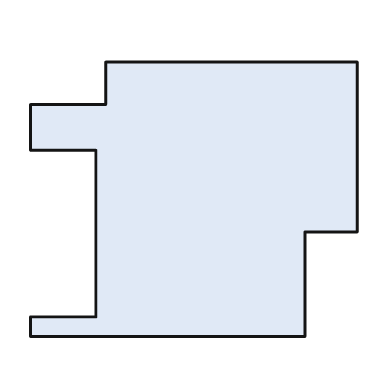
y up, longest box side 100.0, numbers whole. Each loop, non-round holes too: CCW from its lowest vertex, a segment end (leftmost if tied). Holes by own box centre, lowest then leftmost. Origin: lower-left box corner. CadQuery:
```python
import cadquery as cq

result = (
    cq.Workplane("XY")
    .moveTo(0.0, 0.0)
    .lineTo(84.0, 0.0)
    .lineTo(84.0, 32.0)
    .lineTo(100.0, 32.0)
    .lineTo(100.0, 84.0)
    .lineTo(23.0, 84.0)
    .lineTo(23.0, 71.0)
    .lineTo(0.0, 71.0)
    .lineTo(0.0, 57.0)
    .lineTo(20.0, 57.0)
    .lineTo(20.0, 6.0)
    .lineTo(0.0, 6.0)
    .close()
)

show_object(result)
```